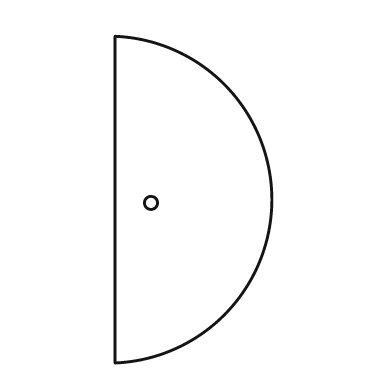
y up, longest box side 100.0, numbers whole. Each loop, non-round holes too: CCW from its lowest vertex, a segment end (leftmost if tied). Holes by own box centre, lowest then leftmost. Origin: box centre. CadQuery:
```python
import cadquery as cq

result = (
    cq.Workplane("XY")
    .moveTo(-24.0, -50.0)
    .threePointArc((24.0, 0.0), (-24.0, 50.0))
    .close()
    .moveTo(-13.0, -1.0)
    .circle(2.0)
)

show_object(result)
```